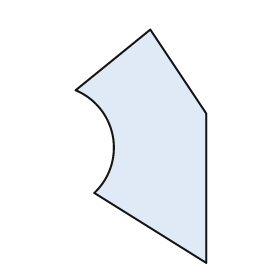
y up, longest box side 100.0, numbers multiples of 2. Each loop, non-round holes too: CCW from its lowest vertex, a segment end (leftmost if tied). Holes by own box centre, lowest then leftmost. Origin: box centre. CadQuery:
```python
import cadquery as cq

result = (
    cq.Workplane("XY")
    .moveTo(28.0, -50.0)
    .lineTo(28.0, 14.0)
    .lineTo(4.0, 50.0)
    .lineTo(-28.0, 24.0)
    .threePointArc((-12.0, 4.0), (-20.0, -20.0))
    .close()
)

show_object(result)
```